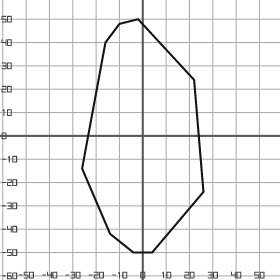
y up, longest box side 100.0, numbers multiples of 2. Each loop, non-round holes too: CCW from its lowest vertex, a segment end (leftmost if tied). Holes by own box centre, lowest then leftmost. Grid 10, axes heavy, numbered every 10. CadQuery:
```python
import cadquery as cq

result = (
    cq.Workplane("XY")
    .moveTo(-4.0, -50.0)
    .lineTo(4.0, -50.0)
    .lineTo(26.0, -24.0)
    .lineTo(22.0, 24.0)
    .lineTo(-2.0, 50.0)
    .lineTo(-10.0, 48.0)
    .lineTo(-16.0, 40.0)
    .lineTo(-26.0, -14.0)
    .lineTo(-14.0, -42.0)
    .close()
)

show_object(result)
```